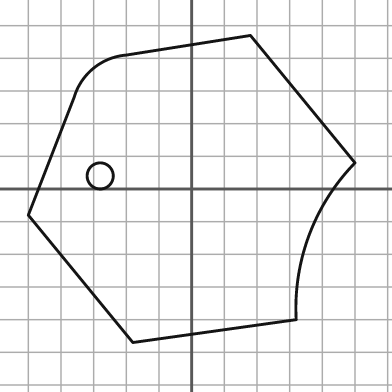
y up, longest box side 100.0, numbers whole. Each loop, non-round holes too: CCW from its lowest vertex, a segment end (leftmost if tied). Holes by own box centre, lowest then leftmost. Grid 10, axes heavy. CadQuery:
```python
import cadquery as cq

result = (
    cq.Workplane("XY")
    .moveTo(-18.0, -47.0)
    .lineTo(32.0, -40.0)
    .threePointArc((36.0, -14.0), (50.0, 8.0))
    .lineTo(18.0, 47.0)
    .lineTo(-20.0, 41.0)
    .threePointArc((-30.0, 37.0), (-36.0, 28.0))
    .lineTo(-50.0, -8.0)
    .close()
    .moveTo(-28.0, 4.0)
    .circle(4.0)
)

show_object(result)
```